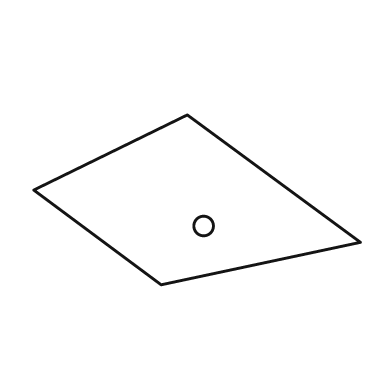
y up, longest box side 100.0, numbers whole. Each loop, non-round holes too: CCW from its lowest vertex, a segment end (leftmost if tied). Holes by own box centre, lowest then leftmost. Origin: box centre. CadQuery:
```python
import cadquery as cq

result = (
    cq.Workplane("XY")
    .moveTo(-11.0, -26.0)
    .lineTo(50.0, -13.0)
    .lineTo(-3.0, 26.0)
    .lineTo(-50.0, 3.0)
    .close()
    .moveTo(2.0, -8.0)
    .circle(3.0)
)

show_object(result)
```